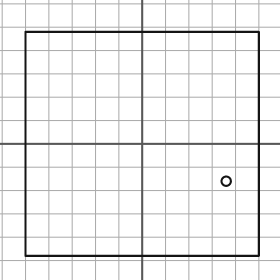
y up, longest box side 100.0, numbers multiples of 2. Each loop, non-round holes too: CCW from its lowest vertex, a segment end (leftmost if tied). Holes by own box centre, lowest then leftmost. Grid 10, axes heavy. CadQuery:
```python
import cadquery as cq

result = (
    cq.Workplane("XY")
    .moveTo(-50.0, -48.0)
    .lineTo(50.0, -48.0)
    .lineTo(50.0, 48.0)
    .lineTo(-50.0, 48.0)
    .close()
    .moveTo(36.0, -16.0)
    .circle(2.0)
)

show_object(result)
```